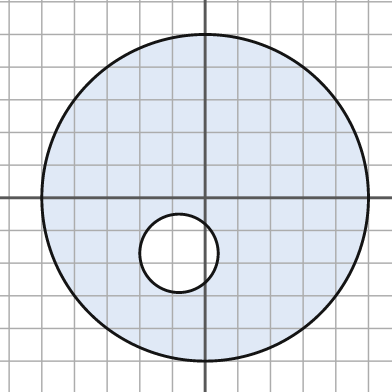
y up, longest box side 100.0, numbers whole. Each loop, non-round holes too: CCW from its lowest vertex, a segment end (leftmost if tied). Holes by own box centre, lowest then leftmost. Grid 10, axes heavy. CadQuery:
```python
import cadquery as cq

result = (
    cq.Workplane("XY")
    .moveTo(0.0, 0.0)
    .circle(50.0)
    .moveTo(-8.0, -17.0)
    .circle(12.0)
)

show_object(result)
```